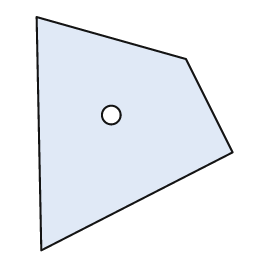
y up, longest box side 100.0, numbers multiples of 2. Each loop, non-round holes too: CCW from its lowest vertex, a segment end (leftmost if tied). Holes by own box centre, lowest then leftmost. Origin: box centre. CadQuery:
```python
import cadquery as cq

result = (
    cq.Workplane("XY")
    .moveTo(-40.0, -50.0)
    .lineTo(42.0, -8.0)
    .lineTo(22.0, 32.0)
    .lineTo(-42.0, 50.0)
    .close()
    .moveTo(-10.0, 8.0)
    .circle(4.0)
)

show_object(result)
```